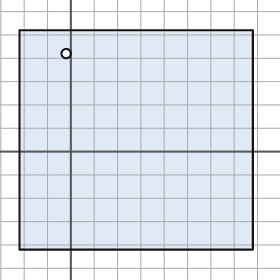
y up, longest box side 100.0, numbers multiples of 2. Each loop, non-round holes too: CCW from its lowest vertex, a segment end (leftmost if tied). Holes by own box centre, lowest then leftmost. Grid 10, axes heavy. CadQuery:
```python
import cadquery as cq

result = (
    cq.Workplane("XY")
    .moveTo(-22.0, -42.0)
    .lineTo(78.0, -42.0)
    .lineTo(78.0, 52.0)
    .lineTo(-22.0, 52.0)
    .close()
    .moveTo(-2.0, 42.0)
    .circle(2.0)
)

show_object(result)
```